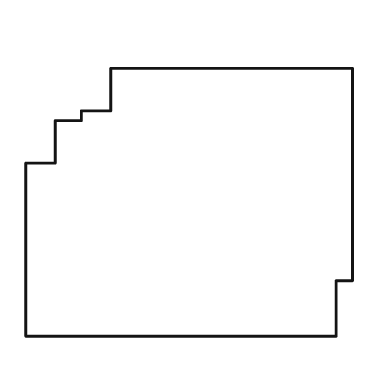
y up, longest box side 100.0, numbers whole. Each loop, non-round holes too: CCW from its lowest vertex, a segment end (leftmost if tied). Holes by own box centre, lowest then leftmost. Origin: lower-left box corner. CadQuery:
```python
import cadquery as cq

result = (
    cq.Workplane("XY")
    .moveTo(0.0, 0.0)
    .lineTo(95.0, 0.0)
    .lineTo(95.0, 17.0)
    .lineTo(100.0, 17.0)
    .lineTo(100.0, 82.0)
    .lineTo(26.0, 82.0)
    .lineTo(26.0, 69.0)
    .lineTo(17.0, 69.0)
    .lineTo(17.0, 66.0)
    .lineTo(9.0, 66.0)
    .lineTo(9.0, 53.0)
    .lineTo(0.0, 53.0)
    .close()
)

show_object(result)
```